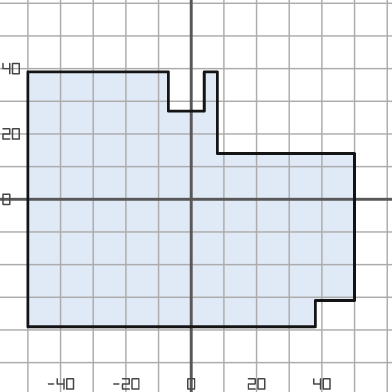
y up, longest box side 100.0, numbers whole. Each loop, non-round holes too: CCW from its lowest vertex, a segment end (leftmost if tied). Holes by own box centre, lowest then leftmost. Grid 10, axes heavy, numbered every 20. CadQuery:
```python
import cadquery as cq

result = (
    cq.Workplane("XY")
    .moveTo(-50.0, -39.0)
    .lineTo(38.0, -39.0)
    .lineTo(38.0, -31.0)
    .lineTo(50.0, -31.0)
    .lineTo(50.0, 14.0)
    .lineTo(8.0, 14.0)
    .lineTo(8.0, 39.0)
    .lineTo(4.0, 39.0)
    .lineTo(4.0, 27.0)
    .lineTo(-7.0, 27.0)
    .lineTo(-7.0, 39.0)
    .lineTo(-50.0, 39.0)
    .close()
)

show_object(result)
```